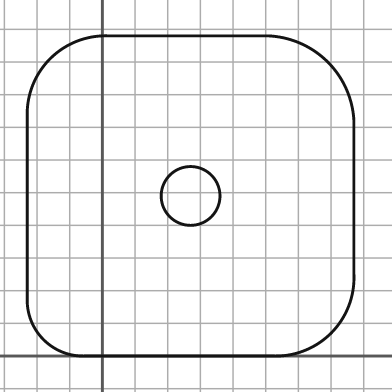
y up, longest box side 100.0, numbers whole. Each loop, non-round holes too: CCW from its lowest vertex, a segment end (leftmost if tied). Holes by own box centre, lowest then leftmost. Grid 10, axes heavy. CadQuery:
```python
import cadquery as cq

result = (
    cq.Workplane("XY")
    .moveTo(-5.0, 0.0)
    .lineTo(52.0, 0.0)
    .threePointArc((70.0, 7.0), (77.0, 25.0))
    .lineTo(77.0, 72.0)
    .threePointArc((69.0, 90.0), (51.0, 98.0))
    .lineTo(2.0, 98.0)
    .threePointArc((-16.0, 91.0), (-23.0, 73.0))
    .lineTo(-23.0, 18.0)
    .threePointArc((-18.0, 5.0), (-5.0, 0.0))
    .close()
    .moveTo(27.0, 49.0)
    .circle(9.0)
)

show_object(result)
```